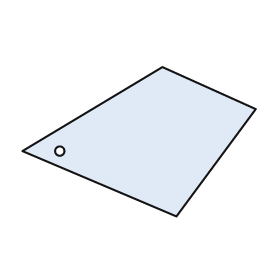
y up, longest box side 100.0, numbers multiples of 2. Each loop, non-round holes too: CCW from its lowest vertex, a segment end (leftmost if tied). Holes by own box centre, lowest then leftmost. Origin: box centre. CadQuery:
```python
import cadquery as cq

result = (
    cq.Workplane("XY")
    .moveTo(16.0, -32.0)
    .lineTo(50.0, 14.0)
    .lineTo(10.0, 32.0)
    .lineTo(-50.0, -4.0)
    .close()
    .moveTo(-34.0, -4.0)
    .circle(2.0)
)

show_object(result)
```